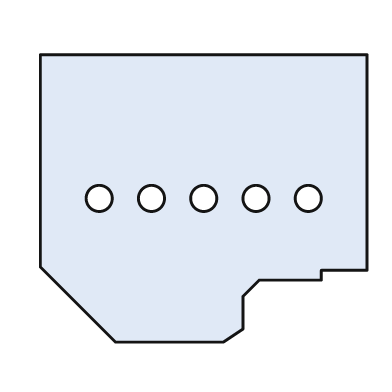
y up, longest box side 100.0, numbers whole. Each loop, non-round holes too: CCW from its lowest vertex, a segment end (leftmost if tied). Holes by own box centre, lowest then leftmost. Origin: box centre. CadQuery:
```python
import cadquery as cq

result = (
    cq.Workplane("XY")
    .moveTo(-27.0, -44.0)
    .lineTo(6.0, -44.0)
    .lineTo(12.0, -40.0)
    .lineTo(12.0, -30.0)
    .lineTo(17.0, -25.0)
    .lineTo(36.0, -25.0)
    .lineTo(36.0, -22.0)
    .lineTo(50.0, -22.0)
    .lineTo(50.0, 44.0)
    .lineTo(-50.0, 44.0)
    .lineTo(-50.0, -21.0)
    .close()
    .moveTo(-32.0, 0.0)
    .circle(4.0)
    .moveTo(-16.0, 0.0)
    .circle(4.0)
    .moveTo(0.0, 0.0)
    .circle(4.0)
    .moveTo(16.0, 0.0)
    .circle(4.0)
    .moveTo(32.0, 0.0)
    .circle(4.0)
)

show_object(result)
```